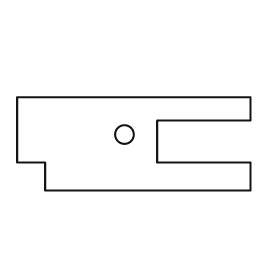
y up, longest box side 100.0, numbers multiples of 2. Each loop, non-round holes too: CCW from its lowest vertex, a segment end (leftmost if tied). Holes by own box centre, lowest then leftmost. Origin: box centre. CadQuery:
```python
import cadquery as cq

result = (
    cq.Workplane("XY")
    .moveTo(-38.0, -20.0)
    .lineTo(50.0, -20.0)
    .lineTo(50.0, -8.0)
    .lineTo(10.0, -8.0)
    .lineTo(10.0, 10.0)
    .lineTo(50.0, 10.0)
    .lineTo(50.0, 20.0)
    .lineTo(-50.0, 20.0)
    .lineTo(-50.0, -8.0)
    .lineTo(-38.0, -8.0)
    .close()
    .moveTo(-4.0, 4.0)
    .circle(4.0)
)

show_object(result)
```